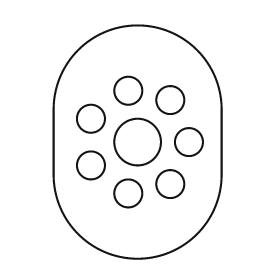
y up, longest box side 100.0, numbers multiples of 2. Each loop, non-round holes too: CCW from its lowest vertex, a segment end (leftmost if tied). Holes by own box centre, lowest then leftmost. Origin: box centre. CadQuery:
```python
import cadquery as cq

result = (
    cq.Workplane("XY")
    .moveTo(-36.0, -14.0)
    .threePointArc((0.0, -50.0), (36.0, -14.0))
    .lineTo(36.0, 14.0)
    .threePointArc((0.0, 50.0), (-36.0, 14.0))
    .close()
    .moveTo(-4.0, -22.0)
    .circle(6.0)
    .moveTo(14.0, -18.0)
    .circle(6.0)
    .moveTo(-20.0, -10.0)
    .circle(6.0)
    .moveTo(0.0, 0.0)
    .circle(10.0)
    .moveTo(22.0, 0.0)
    .circle(6.0)
    .moveTo(-20.0, 10.0)
    .circle(6.0)
    .moveTo(14.0, 18.0)
    .circle(6.0)
    .moveTo(-4.0, 22.0)
    .circle(6.0)
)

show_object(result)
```